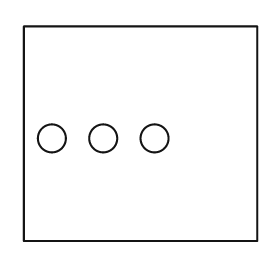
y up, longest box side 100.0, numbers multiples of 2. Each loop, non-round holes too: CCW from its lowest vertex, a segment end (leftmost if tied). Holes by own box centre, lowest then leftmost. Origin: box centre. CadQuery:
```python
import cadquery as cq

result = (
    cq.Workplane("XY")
    .moveTo(-50.0, -46.0)
    .lineTo(50.0, -46.0)
    .lineTo(50.0, 46.0)
    .lineTo(-50.0, 46.0)
    .close()
    .moveTo(-38.0, -2.0)
    .circle(6.0)
    .moveTo(-16.0, -2.0)
    .circle(6.0)
    .moveTo(6.0, -2.0)
    .circle(6.0)
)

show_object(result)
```